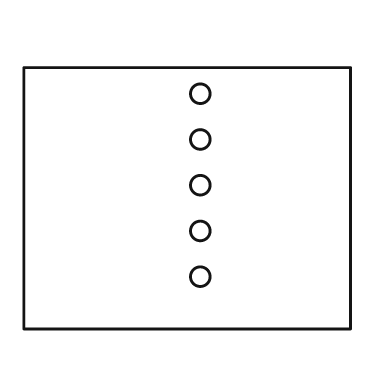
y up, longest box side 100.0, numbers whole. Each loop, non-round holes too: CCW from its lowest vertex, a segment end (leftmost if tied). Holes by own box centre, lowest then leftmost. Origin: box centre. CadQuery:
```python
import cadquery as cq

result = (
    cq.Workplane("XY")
    .moveTo(-50.0, -40.0)
    .lineTo(50.0, -40.0)
    .lineTo(50.0, 40.0)
    .lineTo(-50.0, 40.0)
    .close()
    .moveTo(4.0, -24.0)
    .circle(3.0)
    .moveTo(4.0, -10.0)
    .circle(3.0)
    .moveTo(4.0, 4.0)
    .circle(3.0)
    .moveTo(4.0, 18.0)
    .circle(3.0)
    .moveTo(4.0, 32.0)
    .circle(3.0)
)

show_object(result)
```